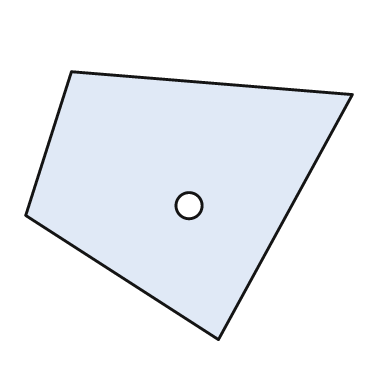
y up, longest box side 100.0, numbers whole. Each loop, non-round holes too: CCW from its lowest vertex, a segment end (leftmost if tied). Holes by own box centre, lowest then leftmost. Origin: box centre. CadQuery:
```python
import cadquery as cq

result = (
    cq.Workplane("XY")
    .moveTo(9.0, -41.0)
    .lineTo(50.0, 34.0)
    .lineTo(-36.0, 41.0)
    .lineTo(-50.0, -3.0)
    .close()
    .moveTo(0.0, 0.0)
    .circle(4.0)
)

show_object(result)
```